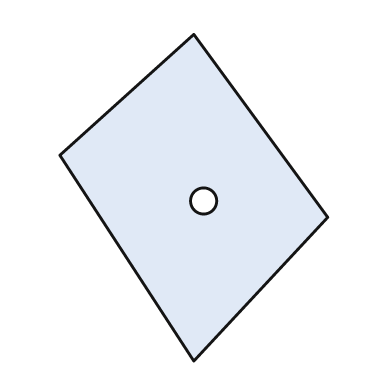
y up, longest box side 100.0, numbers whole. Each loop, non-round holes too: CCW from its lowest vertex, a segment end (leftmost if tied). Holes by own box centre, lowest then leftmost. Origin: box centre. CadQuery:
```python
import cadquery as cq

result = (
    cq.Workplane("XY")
    .moveTo(0.0, -50.0)
    .lineTo(41.0, -6.0)
    .lineTo(0.0, 50.0)
    .lineTo(-41.0, 13.0)
    .close()
    .moveTo(3.0, -1.0)
    .circle(4.0)
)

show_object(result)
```